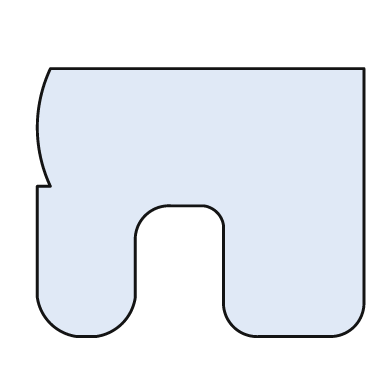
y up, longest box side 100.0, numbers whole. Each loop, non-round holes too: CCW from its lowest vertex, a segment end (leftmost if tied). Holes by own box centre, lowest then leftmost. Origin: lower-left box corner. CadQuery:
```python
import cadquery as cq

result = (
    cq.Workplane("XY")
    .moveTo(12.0, 0.0)
    .lineTo(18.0, 0.0)
    .threePointArc((26.0, 4.0), (30.0, 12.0))
    .lineTo(30.0, 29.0)
    .threePointArc((33.0, 37.0), (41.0, 40.0))
    .lineTo(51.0, 40.0)
    .threePointArc((55.0, 38.0), (57.0, 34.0))
    .lineTo(57.0, 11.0)
    .threePointArc((60.0, 3.0), (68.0, 0.0))
    .lineTo(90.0, 0.0)
    .threePointArc((97.0, 3.0), (100.0, 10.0))
    .lineTo(100.0, 82.0)
    .lineTo(4.0, 82.0)
    .threePointArc((0.0, 64.0), (4.0, 46.0))
    .lineTo(0.0, 46.0)
    .lineTo(0.0, 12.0)
    .threePointArc((4.0, 4.0), (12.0, 0.0))
    .close()
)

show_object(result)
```